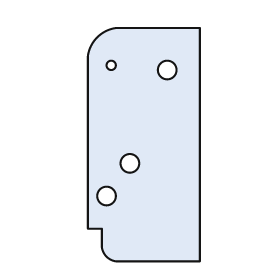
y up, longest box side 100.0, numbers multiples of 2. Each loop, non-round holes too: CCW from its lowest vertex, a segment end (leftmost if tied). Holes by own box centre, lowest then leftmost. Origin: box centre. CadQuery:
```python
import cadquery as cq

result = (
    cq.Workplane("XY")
    .moveTo(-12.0, -50.0)
    .lineTo(24.0, -50.0)
    .lineTo(24.0, 50.0)
    .lineTo(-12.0, 50.0)
    .threePointArc((-20.0, 46.0), (-24.0, 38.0))
    .lineTo(-24.0, -36.0)
    .lineTo(-18.0, -36.0)
    .lineTo(-18.0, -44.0)
    .threePointArc((-16.0, -48.0), (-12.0, -50.0))
    .close()
    .moveTo(-16.0, -22.0)
    .circle(4.0)
    .moveTo(-6.0, -8.0)
    .circle(4.0)
    .moveTo(10.0, 32.0)
    .circle(4.0)
    .moveTo(-14.0, 34.0)
    .circle(2.0)
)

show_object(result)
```